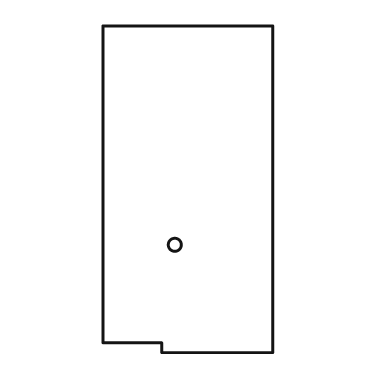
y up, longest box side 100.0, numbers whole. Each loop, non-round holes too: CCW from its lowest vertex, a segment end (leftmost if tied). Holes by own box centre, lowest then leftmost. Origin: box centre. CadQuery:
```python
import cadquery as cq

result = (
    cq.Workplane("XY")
    .moveTo(-8.0, -50.0)
    .lineTo(26.0, -50.0)
    .lineTo(26.0, 50.0)
    .lineTo(-26.0, 50.0)
    .lineTo(-26.0, -47.0)
    .lineTo(-8.0, -47.0)
    .close()
    .moveTo(-4.0, -17.0)
    .circle(2.0)
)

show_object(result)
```